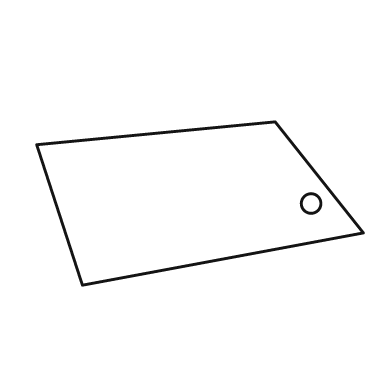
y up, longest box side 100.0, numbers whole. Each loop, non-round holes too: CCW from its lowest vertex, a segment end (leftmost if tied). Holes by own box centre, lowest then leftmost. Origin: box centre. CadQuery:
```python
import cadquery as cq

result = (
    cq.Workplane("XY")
    .moveTo(-36.0, -25.0)
    .lineTo(50.0, -9.0)
    .lineTo(23.0, 25.0)
    .lineTo(-50.0, 18.0)
    .close()
    .moveTo(34.0, 0.0)
    .circle(3.0)
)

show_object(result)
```